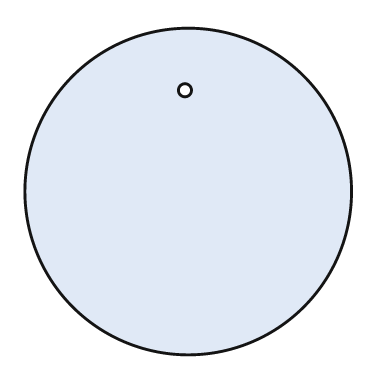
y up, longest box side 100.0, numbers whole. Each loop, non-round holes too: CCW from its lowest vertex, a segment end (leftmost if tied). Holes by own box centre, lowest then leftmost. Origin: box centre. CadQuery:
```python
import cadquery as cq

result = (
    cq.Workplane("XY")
    .moveTo(0.0, 0.0)
    .circle(50.0)
    .moveTo(-1.0, 31.0)
    .circle(2.0)
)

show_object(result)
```